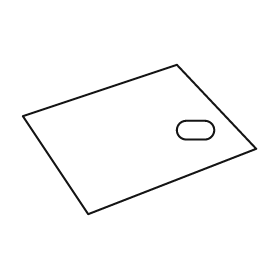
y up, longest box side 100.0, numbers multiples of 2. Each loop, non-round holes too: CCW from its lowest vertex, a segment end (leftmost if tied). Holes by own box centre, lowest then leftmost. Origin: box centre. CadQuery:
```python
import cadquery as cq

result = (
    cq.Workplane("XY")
    .moveTo(-22.0, -32.0)
    .lineTo(50.0, -4.0)
    .lineTo(16.0, 32.0)
    .lineTo(-50.0, 10.0)
    .close()
    .moveTo(20.0, 0.0)
    .lineTo(28.0, 0.0)
    .threePointArc((32.0, 4.0), (28.0, 8.0))
    .lineTo(20.0, 8.0)
    .threePointArc((16.0, 4.0), (20.0, 0.0))
    .close()
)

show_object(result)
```